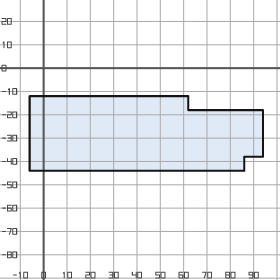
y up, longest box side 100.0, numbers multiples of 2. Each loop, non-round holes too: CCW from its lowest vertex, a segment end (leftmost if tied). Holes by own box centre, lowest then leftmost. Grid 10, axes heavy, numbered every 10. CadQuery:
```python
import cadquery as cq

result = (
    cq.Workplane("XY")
    .moveTo(-6.0, -44.0)
    .lineTo(86.0, -44.0)
    .lineTo(86.0, -38.0)
    .lineTo(94.0, -38.0)
    .lineTo(94.0, -18.0)
    .lineTo(62.0, -18.0)
    .lineTo(62.0, -12.0)
    .lineTo(-6.0, -12.0)
    .close()
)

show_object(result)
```